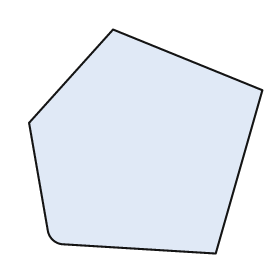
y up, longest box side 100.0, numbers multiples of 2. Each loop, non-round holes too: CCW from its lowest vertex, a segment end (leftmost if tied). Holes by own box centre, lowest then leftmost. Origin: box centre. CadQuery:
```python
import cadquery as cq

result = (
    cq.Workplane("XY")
    .moveTo(30.0, -48.0)
    .lineTo(50.0, 22.0)
    .lineTo(-14.0, 48.0)
    .lineTo(-50.0, 8.0)
    .lineTo(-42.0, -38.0)
    .threePointArc((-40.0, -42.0), (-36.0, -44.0))
    .close()
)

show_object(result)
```